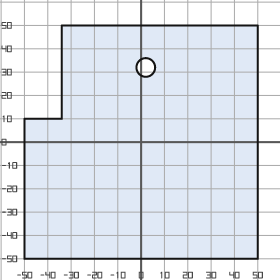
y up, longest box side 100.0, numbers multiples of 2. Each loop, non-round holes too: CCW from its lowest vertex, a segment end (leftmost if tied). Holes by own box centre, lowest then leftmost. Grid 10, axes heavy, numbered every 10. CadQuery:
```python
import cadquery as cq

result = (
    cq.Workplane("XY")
    .moveTo(-50.0, -50.0)
    .lineTo(50.0, -50.0)
    .lineTo(50.0, 50.0)
    .lineTo(-34.0, 50.0)
    .lineTo(-34.0, 10.0)
    .lineTo(-50.0, 10.0)
    .close()
    .moveTo(2.0, 32.0)
    .circle(4.0)
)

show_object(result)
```